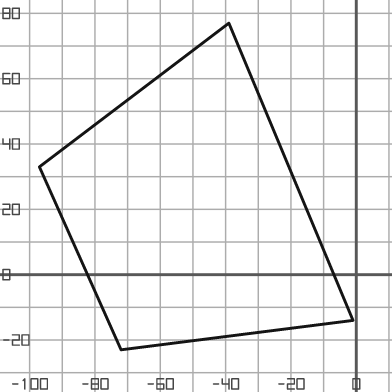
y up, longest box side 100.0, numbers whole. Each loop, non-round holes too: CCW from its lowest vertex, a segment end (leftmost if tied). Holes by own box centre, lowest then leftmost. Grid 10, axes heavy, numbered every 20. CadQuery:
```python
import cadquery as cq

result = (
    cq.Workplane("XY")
    .moveTo(-72.0, -23.0)
    .lineTo(-1.0, -14.0)
    .lineTo(-39.0, 77.0)
    .lineTo(-97.0, 33.0)
    .close()
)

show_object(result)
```